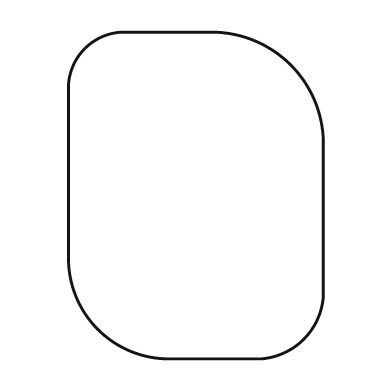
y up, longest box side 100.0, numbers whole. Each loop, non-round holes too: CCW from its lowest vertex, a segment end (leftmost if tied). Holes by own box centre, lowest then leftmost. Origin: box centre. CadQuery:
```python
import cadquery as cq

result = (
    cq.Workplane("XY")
    .moveTo(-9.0, -50.0)
    .lineTo(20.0, -50.0)
    .threePointArc((33.0, -44.0), (39.0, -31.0))
    .lineTo(39.0, 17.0)
    .threePointArc((29.0, 40.0), (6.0, 50.0))
    .lineTo(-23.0, 50.0)
    .threePointArc((-34.0, 45.0), (-39.0, 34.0))
    .lineTo(-39.0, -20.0)
    .threePointArc((-30.0, -41.0), (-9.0, -50.0))
    .close()
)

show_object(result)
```